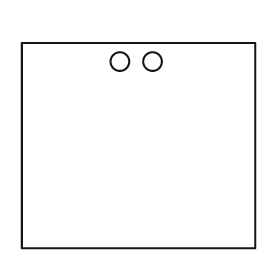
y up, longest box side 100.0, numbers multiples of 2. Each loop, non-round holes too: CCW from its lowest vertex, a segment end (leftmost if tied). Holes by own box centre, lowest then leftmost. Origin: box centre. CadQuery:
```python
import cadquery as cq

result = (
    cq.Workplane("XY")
    .moveTo(-50.0, -44.0)
    .lineTo(50.0, -44.0)
    .lineTo(50.0, 44.0)
    .lineTo(-50.0, 44.0)
    .close()
    .moveTo(-8.0, 36.0)
    .circle(4.0)
    .moveTo(6.0, 36.0)
    .circle(4.0)
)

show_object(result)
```